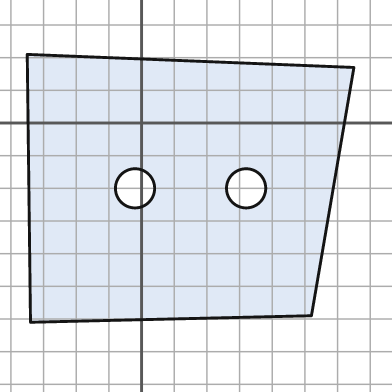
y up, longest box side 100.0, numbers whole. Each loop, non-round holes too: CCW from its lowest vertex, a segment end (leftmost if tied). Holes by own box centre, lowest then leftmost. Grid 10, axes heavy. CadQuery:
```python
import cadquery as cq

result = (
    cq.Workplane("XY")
    .moveTo(-34.0, -61.0)
    .lineTo(52.0, -59.0)
    .lineTo(65.0, 17.0)
    .lineTo(-35.0, 21.0)
    .close()
    .moveTo(-2.0, -20.0)
    .circle(6.0)
    .moveTo(32.0, -20.0)
    .circle(6.0)
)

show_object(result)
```